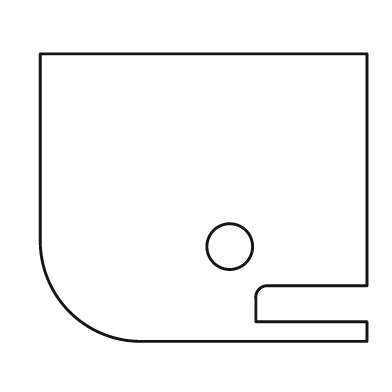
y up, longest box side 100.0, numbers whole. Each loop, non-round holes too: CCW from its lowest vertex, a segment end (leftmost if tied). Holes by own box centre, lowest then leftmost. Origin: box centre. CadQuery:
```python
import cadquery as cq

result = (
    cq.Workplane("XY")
    .moveTo(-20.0, -44.0)
    .lineTo(50.0, -44.0)
    .lineTo(50.0, -38.0)
    .lineTo(16.0, -38.0)
    .lineTo(16.0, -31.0)
    .threePointArc((17.0, -28.0), (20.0, -27.0))
    .lineTo(50.0, -27.0)
    .lineTo(50.0, 44.0)
    .lineTo(-50.0, 44.0)
    .lineTo(-50.0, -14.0)
    .threePointArc((-41.0, -35.0), (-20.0, -44.0))
    .close()
    .moveTo(8.0, -15.0)
    .circle(7.0)
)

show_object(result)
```